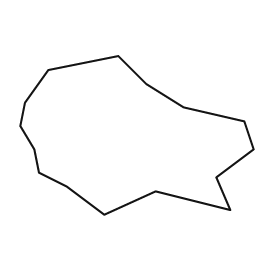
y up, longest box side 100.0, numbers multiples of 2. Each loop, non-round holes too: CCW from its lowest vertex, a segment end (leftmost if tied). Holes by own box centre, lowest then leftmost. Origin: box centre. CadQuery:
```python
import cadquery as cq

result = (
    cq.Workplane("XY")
    .moveTo(-14.0, -34.0)
    .lineTo(8.0, -24.0)
    .lineTo(40.0, -32.0)
    .lineTo(34.0, -18.0)
    .lineTo(50.0, -6.0)
    .lineTo(46.0, 6.0)
    .lineTo(20.0, 12.0)
    .lineTo(4.0, 22.0)
    .lineTo(-8.0, 34.0)
    .lineTo(-38.0, 28.0)
    .lineTo(-48.0, 14.0)
    .lineTo(-50.0, 4.0)
    .lineTo(-44.0, -6.0)
    .lineTo(-42.0, -16.0)
    .lineTo(-30.0, -22.0)
    .close()
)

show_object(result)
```